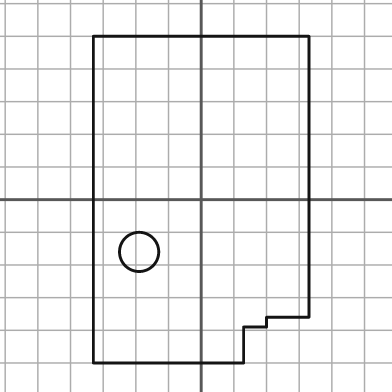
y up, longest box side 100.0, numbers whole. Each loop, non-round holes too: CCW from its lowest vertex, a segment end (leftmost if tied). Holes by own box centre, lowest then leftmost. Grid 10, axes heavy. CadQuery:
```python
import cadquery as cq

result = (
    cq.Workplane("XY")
    .moveTo(-33.0, -50.0)
    .lineTo(13.0, -50.0)
    .lineTo(13.0, -39.0)
    .lineTo(20.0, -39.0)
    .lineTo(20.0, -36.0)
    .lineTo(33.0, -36.0)
    .lineTo(33.0, 50.0)
    .lineTo(-33.0, 50.0)
    .close()
    .moveTo(-19.0, -16.0)
    .circle(6.0)
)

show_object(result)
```